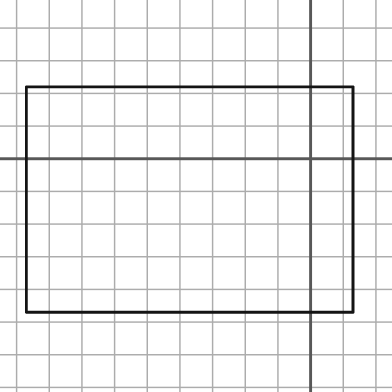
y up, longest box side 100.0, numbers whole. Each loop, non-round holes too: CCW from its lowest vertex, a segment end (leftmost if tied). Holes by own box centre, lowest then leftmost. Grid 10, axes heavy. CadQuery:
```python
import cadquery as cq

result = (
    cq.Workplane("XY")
    .moveTo(-87.0, -47.0)
    .lineTo(13.0, -47.0)
    .lineTo(13.0, 22.0)
    .lineTo(-87.0, 22.0)
    .close()
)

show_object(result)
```